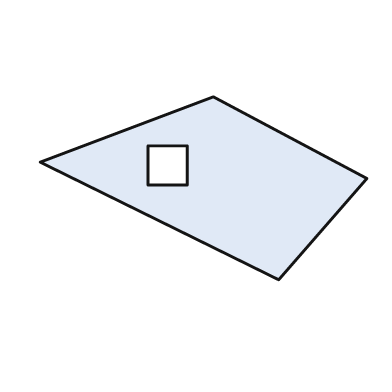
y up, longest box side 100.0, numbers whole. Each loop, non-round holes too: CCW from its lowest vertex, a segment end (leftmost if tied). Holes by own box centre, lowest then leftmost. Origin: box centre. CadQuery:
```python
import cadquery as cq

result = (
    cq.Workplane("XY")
    .moveTo(23.0, -28.0)
    .lineTo(50.0, 3.0)
    .lineTo(3.0, 28.0)
    .lineTo(-50.0, 8.0)
    .close()
    .moveTo(-17.0, 1.0)
    .lineTo(-5.0, 1.0)
    .lineTo(-5.0, 13.0)
    .lineTo(-17.0, 13.0)
    .close()
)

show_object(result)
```